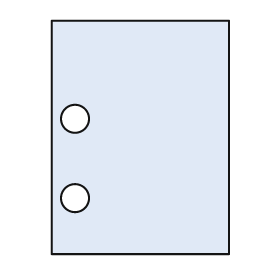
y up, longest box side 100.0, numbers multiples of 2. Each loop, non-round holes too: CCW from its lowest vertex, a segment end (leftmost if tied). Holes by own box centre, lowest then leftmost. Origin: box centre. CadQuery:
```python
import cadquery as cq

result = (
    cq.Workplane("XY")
    .moveTo(-38.0, -50.0)
    .lineTo(38.0, -50.0)
    .lineTo(38.0, 50.0)
    .lineTo(-38.0, 50.0)
    .close()
    .moveTo(-28.0, -26.0)
    .circle(6.0)
    .moveTo(-28.0, 8.0)
    .circle(6.0)
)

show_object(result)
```